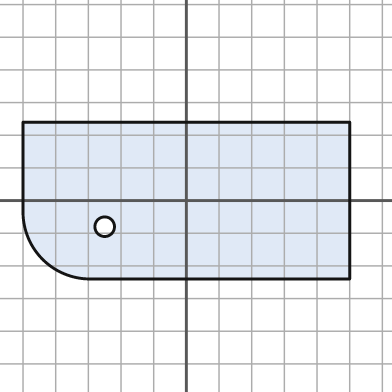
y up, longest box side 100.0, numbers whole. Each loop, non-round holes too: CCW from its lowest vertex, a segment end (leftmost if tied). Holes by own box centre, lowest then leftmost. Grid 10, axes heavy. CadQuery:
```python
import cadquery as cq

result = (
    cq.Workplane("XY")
    .moveTo(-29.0, -24.0)
    .lineTo(50.0, -24.0)
    .lineTo(50.0, 24.0)
    .lineTo(-50.0, 24.0)
    .lineTo(-50.0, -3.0)
    .threePointArc((-44.0, -18.0), (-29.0, -24.0))
    .close()
    .moveTo(-25.0, -8.0)
    .circle(3.0)
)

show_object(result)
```